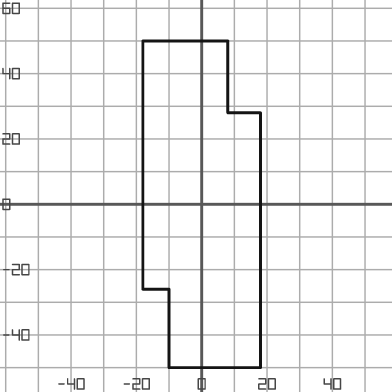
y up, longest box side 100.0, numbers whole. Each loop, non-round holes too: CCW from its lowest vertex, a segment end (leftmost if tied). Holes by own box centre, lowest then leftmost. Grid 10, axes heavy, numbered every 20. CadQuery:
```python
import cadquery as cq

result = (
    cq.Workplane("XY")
    .moveTo(-10.0, -50.0)
    .lineTo(18.0, -50.0)
    .lineTo(18.0, 28.0)
    .lineTo(8.0, 28.0)
    .lineTo(8.0, 50.0)
    .lineTo(-18.0, 50.0)
    .lineTo(-18.0, -26.0)
    .lineTo(-10.0, -26.0)
    .close()
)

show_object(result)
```